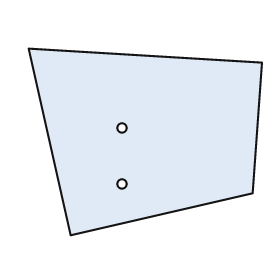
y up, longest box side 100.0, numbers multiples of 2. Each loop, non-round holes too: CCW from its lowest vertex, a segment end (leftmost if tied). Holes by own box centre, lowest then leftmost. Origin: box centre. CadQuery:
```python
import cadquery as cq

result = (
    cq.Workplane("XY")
    .moveTo(-32.0, -40.0)
    .lineTo(46.0, -22.0)
    .lineTo(50.0, 34.0)
    .lineTo(-50.0, 40.0)
    .close()
    .moveTo(-10.0, -18.0)
    .circle(2.0)
    .moveTo(-10.0, 6.0)
    .circle(2.0)
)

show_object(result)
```